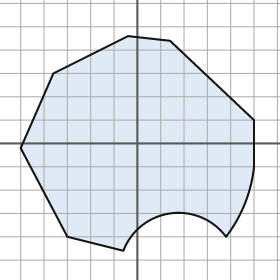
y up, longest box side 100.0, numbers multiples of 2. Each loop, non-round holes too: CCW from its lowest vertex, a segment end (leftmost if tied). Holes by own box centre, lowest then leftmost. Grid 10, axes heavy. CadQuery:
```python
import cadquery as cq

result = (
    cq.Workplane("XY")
    .moveTo(-6.0, -46.0)
    .threePointArc((14.0, -30.0), (38.0, -40.0))
    .threePointArc((46.0, -26.0), (50.0, -10.0))
    .lineTo(50.0, 10.0)
    .lineTo(14.0, 44.0)
    .lineTo(-4.0, 46.0)
    .lineTo(-36.0, 30.0)
    .lineTo(-50.0, -2.0)
    .lineTo(-30.0, -40.0)
    .close()
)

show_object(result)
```